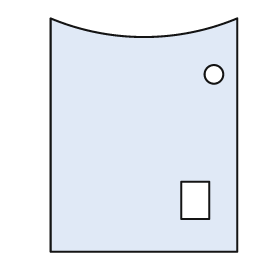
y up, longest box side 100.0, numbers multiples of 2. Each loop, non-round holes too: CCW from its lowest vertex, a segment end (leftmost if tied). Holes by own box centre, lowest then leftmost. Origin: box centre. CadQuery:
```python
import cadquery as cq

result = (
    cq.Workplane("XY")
    .moveTo(-40.0, -50.0)
    .lineTo(40.0, -50.0)
    .lineTo(40.0, 50.0)
    .threePointArc((0.0, 42.0), (-40.0, 50.0))
    .close()
    .moveTo(16.0, -36.0)
    .lineTo(28.0, -36.0)
    .lineTo(28.0, -20.0)
    .lineTo(16.0, -20.0)
    .close()
    .moveTo(30.0, 26.0)
    .circle(4.0)
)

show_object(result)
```